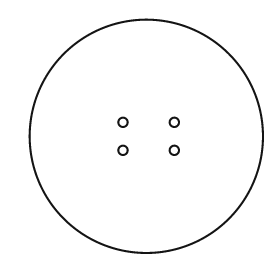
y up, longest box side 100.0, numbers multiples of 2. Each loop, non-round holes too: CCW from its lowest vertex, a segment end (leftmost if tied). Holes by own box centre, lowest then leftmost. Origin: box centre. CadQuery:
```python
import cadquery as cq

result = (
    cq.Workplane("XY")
    .moveTo(0.0, 0.0)
    .circle(50.0)
    .moveTo(-10.0, -6.0)
    .circle(2.0)
    .moveTo(12.0, -6.0)
    .circle(2.0)
    .moveTo(-10.0, 6.0)
    .circle(2.0)
    .moveTo(12.0, 6.0)
    .circle(2.0)
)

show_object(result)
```